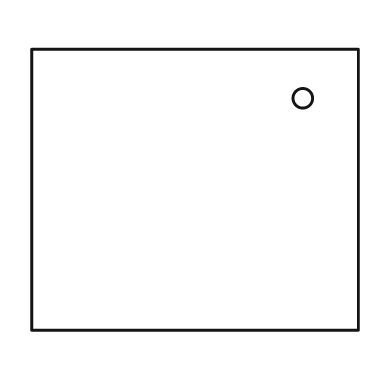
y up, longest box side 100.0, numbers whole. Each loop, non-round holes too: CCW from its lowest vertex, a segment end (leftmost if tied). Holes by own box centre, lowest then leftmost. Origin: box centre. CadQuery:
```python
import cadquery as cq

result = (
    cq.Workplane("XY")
    .moveTo(-50.0, -43.0)
    .lineTo(50.0, -43.0)
    .lineTo(50.0, 43.0)
    .lineTo(-50.0, 43.0)
    .close()
    .moveTo(33.0, 28.0)
    .circle(3.0)
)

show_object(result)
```